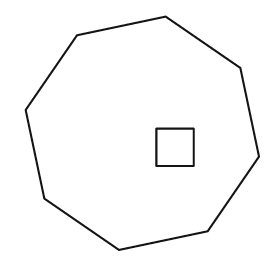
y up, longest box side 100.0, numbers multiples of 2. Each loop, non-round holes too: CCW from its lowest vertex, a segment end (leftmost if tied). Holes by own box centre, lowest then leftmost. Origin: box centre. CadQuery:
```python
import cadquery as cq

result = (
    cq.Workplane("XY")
    .moveTo(-10.0, -50.0)
    .lineTo(28.0, -42.0)
    .lineTo(50.0, -10.0)
    .lineTo(42.0, 28.0)
    .lineTo(10.0, 50.0)
    .lineTo(-28.0, 42.0)
    .lineTo(-50.0, 10.0)
    .lineTo(-42.0, -28.0)
    .close()
    .moveTo(6.0, -14.0)
    .lineTo(22.0, -14.0)
    .lineTo(22.0, 2.0)
    .lineTo(6.0, 2.0)
    .close()
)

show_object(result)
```